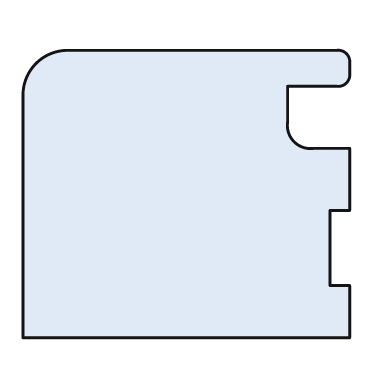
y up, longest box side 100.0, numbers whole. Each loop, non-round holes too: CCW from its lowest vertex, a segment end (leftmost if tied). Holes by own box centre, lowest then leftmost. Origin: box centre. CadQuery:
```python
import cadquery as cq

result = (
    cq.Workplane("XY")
    .moveTo(-50.0, -44.0)
    .lineTo(50.0, -44.0)
    .lineTo(50.0, -28.0)
    .lineTo(44.0, -28.0)
    .lineTo(44.0, -5.0)
    .lineTo(50.0, -5.0)
    .lineTo(50.0, 14.0)
    .lineTo(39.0, 14.0)
    .threePointArc((33.0, 16.0), (31.0, 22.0))
    .lineTo(31.0, 33.0)
    .lineTo(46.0, 33.0)
    .threePointArc((49.0, 34.0), (50.0, 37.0))
    .lineTo(50.0, 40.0)
    .threePointArc((49.0, 43.0), (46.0, 44.0))
    .lineTo(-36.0, 44.0)
    .threePointArc((-46.0, 40.0), (-50.0, 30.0))
    .close()
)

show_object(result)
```